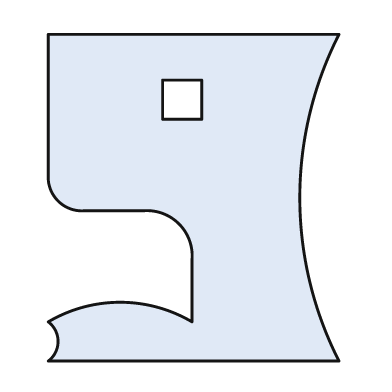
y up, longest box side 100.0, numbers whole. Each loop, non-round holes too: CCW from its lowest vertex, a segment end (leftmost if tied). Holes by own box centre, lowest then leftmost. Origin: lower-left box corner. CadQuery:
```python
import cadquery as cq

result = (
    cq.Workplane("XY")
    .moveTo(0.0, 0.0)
    .lineTo(89.0, 0.0)
    .threePointArc((77.0, 50.0), (89.0, 100.0))
    .lineTo(0.0, 100.0)
    .lineTo(0.0, 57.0)
    .threePointArc((3.0, 49.0), (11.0, 46.0))
    .lineTo(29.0, 46.0)
    .threePointArc((40.0, 42.0), (44.0, 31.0))
    .lineTo(44.0, 12.0)
    .threePointArc((22.0, 18.0), (0.0, 12.0))
    .threePointArc((3.0, 6.0), (0.0, 0.0))
    .close()
    .moveTo(35.0, 74.0)
    .lineTo(47.0, 74.0)
    .lineTo(47.0, 86.0)
    .lineTo(35.0, 86.0)
    .close()
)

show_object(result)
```